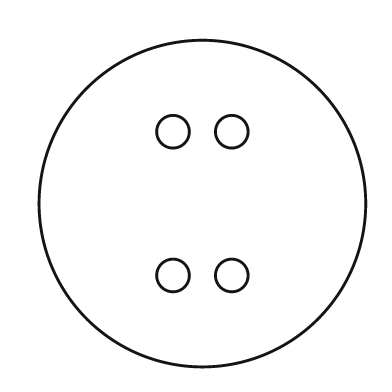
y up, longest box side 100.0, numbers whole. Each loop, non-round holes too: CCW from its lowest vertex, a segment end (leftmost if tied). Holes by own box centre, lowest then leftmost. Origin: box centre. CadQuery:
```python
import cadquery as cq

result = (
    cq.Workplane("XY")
    .moveTo(0.0, 0.0)
    .circle(50.0)
    .moveTo(-9.0, -22.0)
    .circle(5.0)
    .moveTo(9.0, -22.0)
    .circle(5.0)
    .moveTo(-9.0, 22.0)
    .circle(5.0)
    .moveTo(9.0, 22.0)
    .circle(5.0)
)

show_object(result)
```